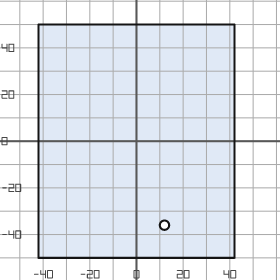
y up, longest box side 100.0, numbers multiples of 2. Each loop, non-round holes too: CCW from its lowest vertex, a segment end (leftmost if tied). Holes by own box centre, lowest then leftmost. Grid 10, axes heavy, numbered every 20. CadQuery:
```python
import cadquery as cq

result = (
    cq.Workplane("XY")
    .moveTo(-42.0, -50.0)
    .lineTo(42.0, -50.0)
    .lineTo(42.0, 50.0)
    .lineTo(-42.0, 50.0)
    .close()
    .moveTo(12.0, -36.0)
    .circle(2.0)
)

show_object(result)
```